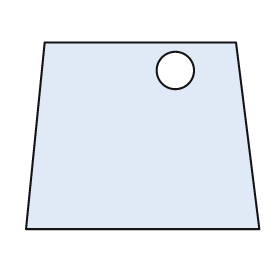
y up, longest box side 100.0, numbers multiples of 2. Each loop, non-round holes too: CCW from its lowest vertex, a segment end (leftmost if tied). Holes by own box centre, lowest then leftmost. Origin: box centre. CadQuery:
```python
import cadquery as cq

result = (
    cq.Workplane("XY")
    .moveTo(-50.0, -40.0)
    .lineTo(50.0, -40.0)
    .lineTo(40.0, 40.0)
    .lineTo(-42.0, 40.0)
    .close()
    .moveTo(14.0, 28.0)
    .circle(8.0)
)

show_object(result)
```